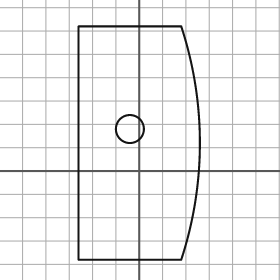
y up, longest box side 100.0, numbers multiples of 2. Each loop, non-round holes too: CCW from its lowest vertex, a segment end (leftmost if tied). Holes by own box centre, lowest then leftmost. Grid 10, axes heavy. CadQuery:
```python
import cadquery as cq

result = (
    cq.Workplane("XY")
    .moveTo(-26.0, -38.0)
    .lineTo(18.0, -38.0)
    .threePointArc((26.0, 12.0), (18.0, 62.0))
    .lineTo(-26.0, 62.0)
    .close()
    .moveTo(-4.0, 18.0)
    .circle(6.0)
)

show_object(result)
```